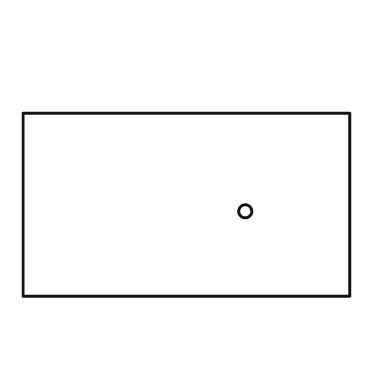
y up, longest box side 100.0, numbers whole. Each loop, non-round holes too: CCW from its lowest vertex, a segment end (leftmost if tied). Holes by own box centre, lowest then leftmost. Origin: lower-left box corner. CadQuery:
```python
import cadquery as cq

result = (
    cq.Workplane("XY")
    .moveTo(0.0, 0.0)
    .lineTo(100.0, 0.0)
    .lineTo(100.0, 56.0)
    .lineTo(0.0, 56.0)
    .close()
    .moveTo(68.0, 26.0)
    .circle(2.0)
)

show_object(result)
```